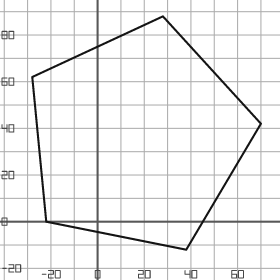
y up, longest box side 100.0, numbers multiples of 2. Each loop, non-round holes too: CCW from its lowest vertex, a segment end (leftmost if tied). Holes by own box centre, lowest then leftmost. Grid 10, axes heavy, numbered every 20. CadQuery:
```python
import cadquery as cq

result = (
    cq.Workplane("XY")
    .moveTo(38.0, -12.0)
    .lineTo(70.0, 42.0)
    .lineTo(28.0, 88.0)
    .lineTo(-28.0, 62.0)
    .lineTo(-22.0, 0.0)
    .close()
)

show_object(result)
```